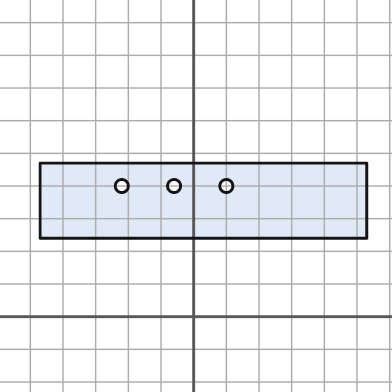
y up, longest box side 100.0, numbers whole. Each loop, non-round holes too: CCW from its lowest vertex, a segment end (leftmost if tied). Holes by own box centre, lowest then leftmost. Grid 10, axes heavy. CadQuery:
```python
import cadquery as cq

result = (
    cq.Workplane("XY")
    .moveTo(-47.0, 24.0)
    .lineTo(53.0, 24.0)
    .lineTo(53.0, 47.0)
    .lineTo(-47.0, 47.0)
    .close()
    .moveTo(-22.0, 40.0)
    .circle(2.0)
    .moveTo(-6.0, 40.0)
    .circle(2.0)
    .moveTo(10.0, 40.0)
    .circle(2.0)
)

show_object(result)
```